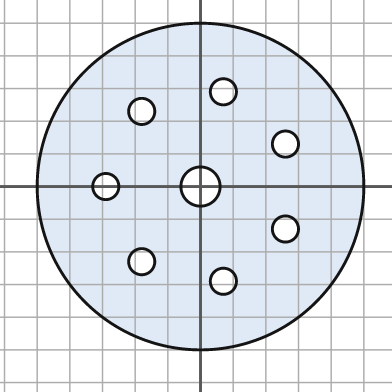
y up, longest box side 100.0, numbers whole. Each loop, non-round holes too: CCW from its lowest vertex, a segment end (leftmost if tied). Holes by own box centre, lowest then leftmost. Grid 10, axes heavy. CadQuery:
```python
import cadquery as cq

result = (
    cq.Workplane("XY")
    .moveTo(0.0, 0.0)
    .circle(50.0)
    .moveTo(7.0, -29.0)
    .circle(4.0)
    .moveTo(-18.0, -23.0)
    .circle(4.0)
    .moveTo(26.0, -13.0)
    .circle(4.0)
    .moveTo(-29.0, 0.0)
    .circle(4.0)
    .moveTo(0.0, 0.0)
    .circle(6.0)
    .moveTo(26.0, 13.0)
    .circle(4.0)
    .moveTo(-18.0, 23.0)
    .circle(4.0)
    .moveTo(7.0, 29.0)
    .circle(4.0)
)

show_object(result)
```